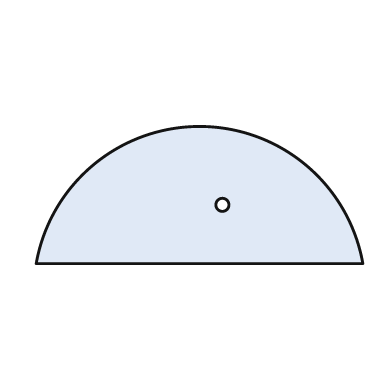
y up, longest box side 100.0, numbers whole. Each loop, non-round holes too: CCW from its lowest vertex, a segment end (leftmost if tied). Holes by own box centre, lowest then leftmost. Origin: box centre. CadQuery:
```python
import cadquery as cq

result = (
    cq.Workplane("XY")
    .moveTo(-50.0, -21.0)
    .lineTo(50.0, -21.0)
    .threePointArc((0.0, 21.0), (-50.0, -21.0))
    .close()
    .moveTo(7.0, -3.0)
    .circle(2.0)
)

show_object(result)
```